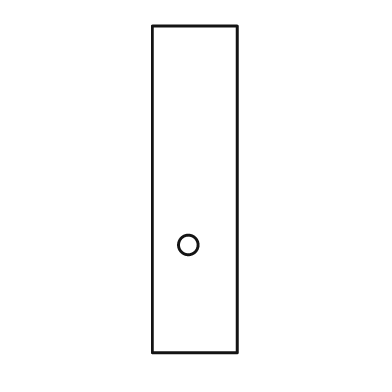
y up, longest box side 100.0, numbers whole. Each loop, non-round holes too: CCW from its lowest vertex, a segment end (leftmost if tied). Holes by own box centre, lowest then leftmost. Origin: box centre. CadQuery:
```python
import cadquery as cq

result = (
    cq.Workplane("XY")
    .moveTo(-13.0, -50.0)
    .lineTo(13.0, -50.0)
    .lineTo(13.0, 50.0)
    .lineTo(-13.0, 50.0)
    .close()
    .moveTo(-2.0, -17.0)
    .circle(3.0)
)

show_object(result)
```